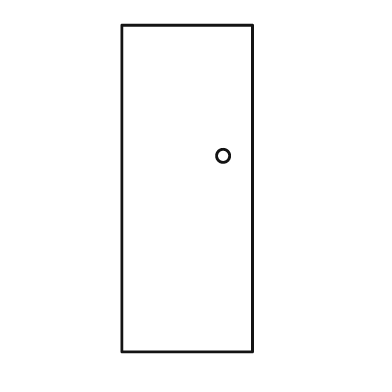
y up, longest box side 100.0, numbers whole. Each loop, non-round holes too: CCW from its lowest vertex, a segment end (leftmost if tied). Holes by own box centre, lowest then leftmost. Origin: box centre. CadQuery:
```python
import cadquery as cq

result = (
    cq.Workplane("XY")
    .moveTo(-20.0, -50.0)
    .lineTo(20.0, -50.0)
    .lineTo(20.0, 50.0)
    .lineTo(-20.0, 50.0)
    .close()
    .moveTo(11.0, 10.0)
    .circle(2.0)
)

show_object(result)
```